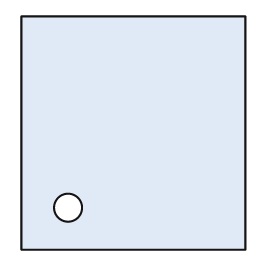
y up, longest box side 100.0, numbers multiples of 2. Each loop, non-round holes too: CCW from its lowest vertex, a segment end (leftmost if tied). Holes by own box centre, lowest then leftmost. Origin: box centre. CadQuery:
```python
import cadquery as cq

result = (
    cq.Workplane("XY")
    .moveTo(-48.0, -50.0)
    .lineTo(48.0, -50.0)
    .lineTo(48.0, 50.0)
    .lineTo(-48.0, 50.0)
    .close()
    .moveTo(-28.0, -32.0)
    .circle(6.0)
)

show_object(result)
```